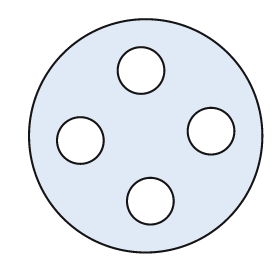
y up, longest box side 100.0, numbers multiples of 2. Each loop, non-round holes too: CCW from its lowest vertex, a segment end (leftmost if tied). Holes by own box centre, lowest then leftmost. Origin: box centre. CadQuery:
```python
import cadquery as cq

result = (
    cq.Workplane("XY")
    .moveTo(0.0, 0.0)
    .circle(50.0)
    .moveTo(2.0, -28.0)
    .circle(10.0)
    .moveTo(-28.0, -2.0)
    .circle(10.0)
    .moveTo(28.0, 2.0)
    .circle(10.0)
    .moveTo(-2.0, 28.0)
    .circle(10.0)
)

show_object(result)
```